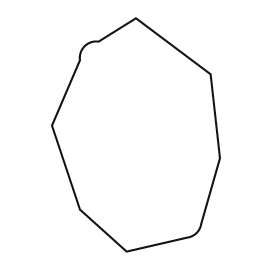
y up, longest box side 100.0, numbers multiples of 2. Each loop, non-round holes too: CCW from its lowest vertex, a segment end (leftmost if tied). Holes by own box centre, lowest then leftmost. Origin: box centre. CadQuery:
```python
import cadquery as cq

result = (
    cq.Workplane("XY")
    .moveTo(-4.0, -50.0)
    .lineTo(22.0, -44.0)
    .threePointArc((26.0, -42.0), (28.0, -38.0))
    .lineTo(36.0, -10.0)
    .lineTo(32.0, 26.0)
    .lineTo(0.0, 50.0)
    .lineTo(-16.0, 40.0)
    .threePointArc((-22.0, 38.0), (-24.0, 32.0))
    .lineTo(-36.0, 4.0)
    .lineTo(-24.0, -32.0)
    .close()
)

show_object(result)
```